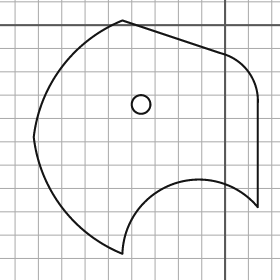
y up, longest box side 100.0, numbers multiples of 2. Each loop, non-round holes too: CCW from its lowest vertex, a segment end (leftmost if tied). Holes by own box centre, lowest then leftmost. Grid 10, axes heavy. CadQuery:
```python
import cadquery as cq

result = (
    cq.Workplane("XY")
    .moveTo(-44.0, -98.0)
    .threePointArc((-22.0, -68.0), (14.0, -78.0))
    .lineTo(14.0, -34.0)
    .threePointArc((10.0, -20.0), (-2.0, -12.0))
    .lineTo(-44.0, 2.0)
    .threePointArc((-70.0, -18.0), (-82.0, -48.0))
    .threePointArc((-70.0, -78.0), (-44.0, -98.0))
    .close()
    .moveTo(-36.0, -34.0)
    .circle(4.0)
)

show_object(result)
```